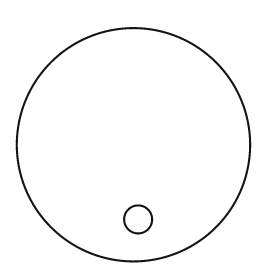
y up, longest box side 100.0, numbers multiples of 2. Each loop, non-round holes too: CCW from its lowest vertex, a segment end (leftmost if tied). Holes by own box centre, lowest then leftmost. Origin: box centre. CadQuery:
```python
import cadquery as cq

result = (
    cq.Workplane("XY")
    .moveTo(0.0, 0.0)
    .circle(50.0)
    .moveTo(2.0, -32.0)
    .circle(6.0)
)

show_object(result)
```